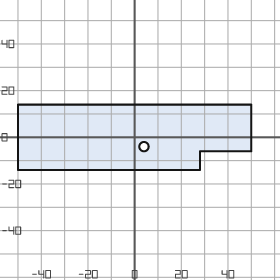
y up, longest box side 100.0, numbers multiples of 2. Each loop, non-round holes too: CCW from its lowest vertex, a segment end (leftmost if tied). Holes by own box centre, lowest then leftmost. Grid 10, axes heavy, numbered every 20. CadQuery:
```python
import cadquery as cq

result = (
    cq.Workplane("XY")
    .moveTo(-50.0, -14.0)
    .lineTo(28.0, -14.0)
    .lineTo(28.0, -6.0)
    .lineTo(50.0, -6.0)
    .lineTo(50.0, 14.0)
    .lineTo(-50.0, 14.0)
    .close()
    .moveTo(4.0, -4.0)
    .circle(2.0)
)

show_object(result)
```